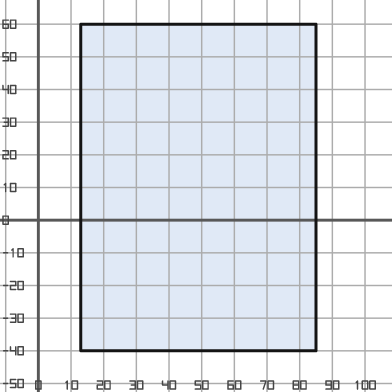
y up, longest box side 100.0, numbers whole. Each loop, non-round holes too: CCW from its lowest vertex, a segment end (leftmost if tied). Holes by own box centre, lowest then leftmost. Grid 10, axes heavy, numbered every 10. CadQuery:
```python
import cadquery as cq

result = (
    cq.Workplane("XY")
    .moveTo(13.0, -40.0)
    .lineTo(85.0, -40.0)
    .lineTo(85.0, 60.0)
    .lineTo(13.0, 60.0)
    .close()
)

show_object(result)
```